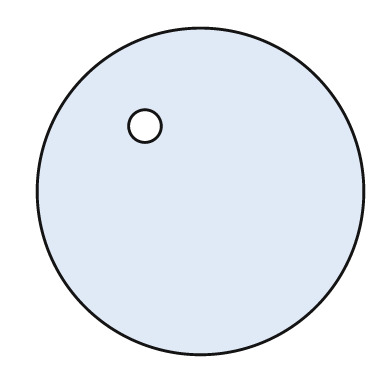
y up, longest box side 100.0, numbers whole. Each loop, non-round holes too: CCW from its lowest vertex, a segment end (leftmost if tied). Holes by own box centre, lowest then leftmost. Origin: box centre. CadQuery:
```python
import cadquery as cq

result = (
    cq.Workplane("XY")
    .moveTo(0.0, 0.0)
    .circle(50.0)
    .moveTo(-17.0, 20.0)
    .circle(5.0)
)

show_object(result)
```